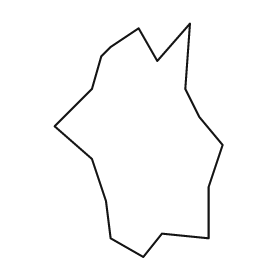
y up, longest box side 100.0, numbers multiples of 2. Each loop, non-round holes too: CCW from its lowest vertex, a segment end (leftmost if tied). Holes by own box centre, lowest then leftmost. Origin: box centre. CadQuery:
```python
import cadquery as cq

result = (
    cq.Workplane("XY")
    .moveTo(2.0, -50.0)
    .lineTo(10.0, -40.0)
    .lineTo(30.0, -42.0)
    .lineTo(30.0, -20.0)
    .lineTo(36.0, -2.0)
    .lineTo(26.0, 10.0)
    .lineTo(20.0, 22.0)
    .lineTo(22.0, 50.0)
    .lineTo(8.0, 34.0)
    .lineTo(0.0, 48.0)
    .lineTo(-12.0, 40.0)
    .lineTo(-16.0, 36.0)
    .lineTo(-20.0, 22.0)
    .lineTo(-36.0, 6.0)
    .lineTo(-20.0, -8.0)
    .lineTo(-14.0, -26.0)
    .lineTo(-12.0, -42.0)
    .close()
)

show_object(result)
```